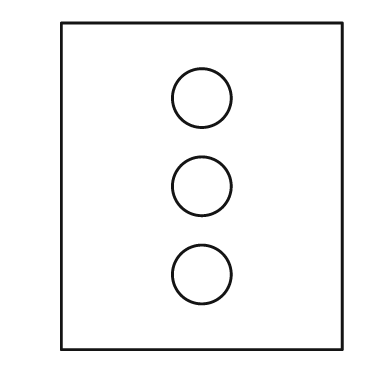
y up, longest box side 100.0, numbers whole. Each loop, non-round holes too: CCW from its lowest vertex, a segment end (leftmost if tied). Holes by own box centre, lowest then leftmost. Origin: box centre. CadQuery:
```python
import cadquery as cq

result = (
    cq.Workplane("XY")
    .moveTo(-43.0, -50.0)
    .lineTo(43.0, -50.0)
    .lineTo(43.0, 50.0)
    .lineTo(-43.0, 50.0)
    .close()
    .moveTo(0.0, -27.0)
    .circle(9.0)
    .moveTo(0.0, 0.0)
    .circle(9.0)
    .moveTo(0.0, 27.0)
    .circle(9.0)
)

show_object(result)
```